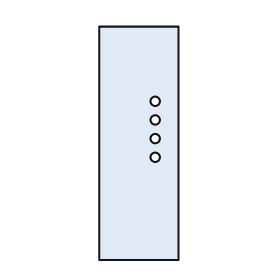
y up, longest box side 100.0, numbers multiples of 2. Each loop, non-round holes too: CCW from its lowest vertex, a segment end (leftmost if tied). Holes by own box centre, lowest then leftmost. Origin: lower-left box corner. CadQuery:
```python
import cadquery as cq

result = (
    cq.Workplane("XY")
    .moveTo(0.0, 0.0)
    .lineTo(34.0, 0.0)
    .lineTo(34.0, 100.0)
    .lineTo(0.0, 100.0)
    .close()
    .moveTo(24.0, 44.0)
    .circle(2.0)
    .moveTo(24.0, 52.0)
    .circle(2.0)
    .moveTo(24.0, 60.0)
    .circle(2.0)
    .moveTo(24.0, 68.0)
    .circle(2.0)
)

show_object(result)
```